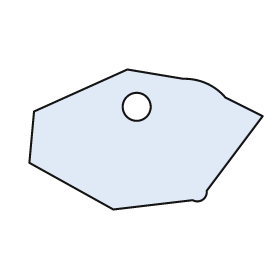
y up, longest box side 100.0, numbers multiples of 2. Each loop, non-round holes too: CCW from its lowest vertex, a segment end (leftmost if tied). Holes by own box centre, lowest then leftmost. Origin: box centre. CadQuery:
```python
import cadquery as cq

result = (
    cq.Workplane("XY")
    .moveTo(-14.0, -30.0)
    .lineTo(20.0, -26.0)
    .threePointArc((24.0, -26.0), (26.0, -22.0))
    .lineTo(50.0, 10.0)
    .lineTo(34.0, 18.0)
    .threePointArc((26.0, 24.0), (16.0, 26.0))
    .lineTo(-8.0, 30.0)
    .lineTo(-48.0, 12.0)
    .lineTo(-50.0, -10.0)
    .close()
    .moveTo(-4.0, 14.0)
    .circle(6.0)
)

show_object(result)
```